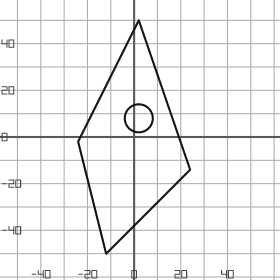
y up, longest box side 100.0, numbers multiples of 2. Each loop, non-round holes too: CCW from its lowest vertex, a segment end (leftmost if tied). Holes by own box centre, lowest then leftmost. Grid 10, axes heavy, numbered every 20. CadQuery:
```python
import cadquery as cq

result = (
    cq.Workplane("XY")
    .moveTo(-12.0, -50.0)
    .lineTo(24.0, -14.0)
    .lineTo(2.0, 50.0)
    .lineTo(-24.0, -2.0)
    .close()
    .moveTo(2.0, 8.0)
    .circle(6.0)
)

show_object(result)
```